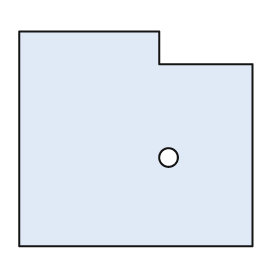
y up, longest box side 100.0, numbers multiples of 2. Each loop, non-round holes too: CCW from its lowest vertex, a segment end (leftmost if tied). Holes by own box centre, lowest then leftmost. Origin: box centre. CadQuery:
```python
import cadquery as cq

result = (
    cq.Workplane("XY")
    .moveTo(-50.0, -46.0)
    .lineTo(50.0, -46.0)
    .lineTo(50.0, 32.0)
    .lineTo(10.0, 32.0)
    .lineTo(10.0, 46.0)
    .lineTo(-50.0, 46.0)
    .close()
    .moveTo(14.0, -8.0)
    .circle(4.0)
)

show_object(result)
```